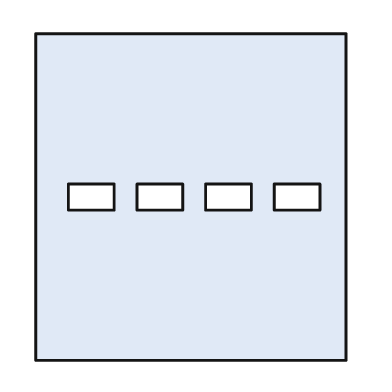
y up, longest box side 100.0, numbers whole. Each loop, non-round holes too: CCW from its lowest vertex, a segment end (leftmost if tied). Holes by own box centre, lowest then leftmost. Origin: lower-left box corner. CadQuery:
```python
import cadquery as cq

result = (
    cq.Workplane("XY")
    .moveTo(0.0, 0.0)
    .lineTo(95.0, 0.0)
    .lineTo(95.0, 100.0)
    .lineTo(0.0, 100.0)
    .close()
    .moveTo(10.0, 46.0)
    .lineTo(24.0, 46.0)
    .lineTo(24.0, 54.0)
    .lineTo(10.0, 54.0)
    .close()
    .moveTo(31.0, 46.0)
    .lineTo(45.0, 46.0)
    .lineTo(45.0, 54.0)
    .lineTo(31.0, 54.0)
    .close()
    .moveTo(52.0, 46.0)
    .lineTo(66.0, 46.0)
    .lineTo(66.0, 54.0)
    .lineTo(52.0, 54.0)
    .close()
    .moveTo(73.0, 46.0)
    .lineTo(87.0, 46.0)
    .lineTo(87.0, 54.0)
    .lineTo(73.0, 54.0)
    .close()
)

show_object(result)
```